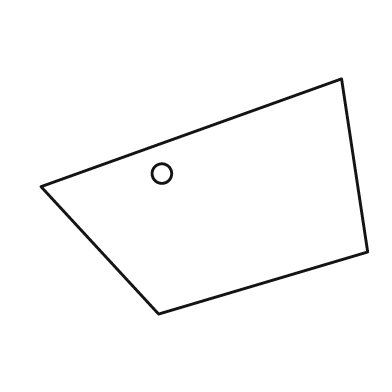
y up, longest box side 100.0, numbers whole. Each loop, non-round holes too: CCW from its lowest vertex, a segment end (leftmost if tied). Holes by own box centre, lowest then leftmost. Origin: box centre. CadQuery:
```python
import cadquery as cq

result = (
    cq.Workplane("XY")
    .moveTo(-14.0, -36.0)
    .lineTo(50.0, -17.0)
    .lineTo(42.0, 36.0)
    .lineTo(-50.0, 3.0)
    .close()
    .moveTo(-13.0, 7.0)
    .circle(3.0)
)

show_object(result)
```